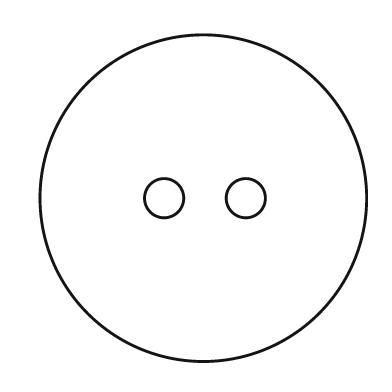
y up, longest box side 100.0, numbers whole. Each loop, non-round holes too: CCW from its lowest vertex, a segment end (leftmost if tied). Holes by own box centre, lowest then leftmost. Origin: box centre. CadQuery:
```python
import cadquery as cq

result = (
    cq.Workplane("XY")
    .moveTo(0.0, 0.0)
    .circle(50.0)
    .moveTo(-12.0, 0.0)
    .circle(6.0)
    .moveTo(13.0, 0.0)
    .circle(6.0)
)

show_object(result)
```